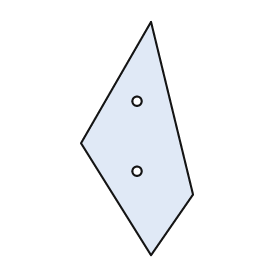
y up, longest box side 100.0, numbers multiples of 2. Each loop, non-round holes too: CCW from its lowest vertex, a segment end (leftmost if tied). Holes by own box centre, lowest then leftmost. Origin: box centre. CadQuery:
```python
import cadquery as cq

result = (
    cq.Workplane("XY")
    .moveTo(6.0, -50.0)
    .lineTo(24.0, -24.0)
    .lineTo(6.0, 50.0)
    .lineTo(-24.0, -2.0)
    .close()
    .moveTo(0.0, -14.0)
    .circle(2.0)
    .moveTo(0.0, 16.0)
    .circle(2.0)
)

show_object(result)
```